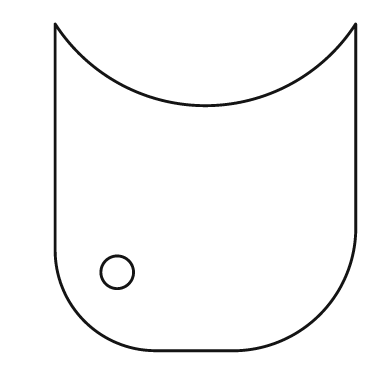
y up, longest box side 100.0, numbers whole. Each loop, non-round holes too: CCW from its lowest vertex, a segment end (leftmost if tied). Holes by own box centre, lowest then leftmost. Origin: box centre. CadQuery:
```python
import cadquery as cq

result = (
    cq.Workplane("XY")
    .moveTo(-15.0, -50.0)
    .lineTo(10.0, -50.0)
    .threePointArc((35.0, -39.0), (46.0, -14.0))
    .lineTo(46.0, 50.0)
    .threePointArc((0.0, 25.0), (-46.0, 50.0))
    .lineTo(-46.0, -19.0)
    .threePointArc((-37.0, -41.0), (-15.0, -50.0))
    .close()
    .moveTo(-27.0, -26.0)
    .circle(5.0)
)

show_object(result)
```